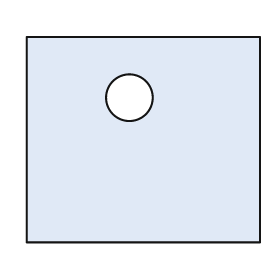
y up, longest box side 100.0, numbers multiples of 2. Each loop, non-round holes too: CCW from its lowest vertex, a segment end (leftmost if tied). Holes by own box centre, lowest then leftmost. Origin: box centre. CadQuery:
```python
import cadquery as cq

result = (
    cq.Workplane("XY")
    .moveTo(-50.0, -44.0)
    .lineTo(50.0, -44.0)
    .lineTo(50.0, 44.0)
    .lineTo(-50.0, 44.0)
    .close()
    .moveTo(-6.0, 18.0)
    .circle(10.0)
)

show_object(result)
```